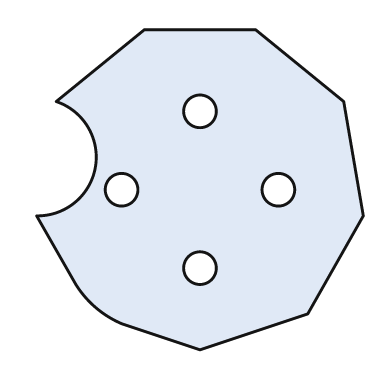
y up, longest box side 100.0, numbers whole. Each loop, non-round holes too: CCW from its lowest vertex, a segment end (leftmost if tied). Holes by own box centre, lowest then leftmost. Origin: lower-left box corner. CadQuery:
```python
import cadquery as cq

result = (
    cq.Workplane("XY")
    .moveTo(50.0, 0.0)
    .lineTo(83.0, 11.0)
    .lineTo(100.0, 41.0)
    .lineTo(94.0, 76.0)
    .lineTo(67.0, 98.0)
    .lineTo(33.0, 98.0)
    .lineTo(6.0, 76.0)
    .threePointArc((18.0, 56.0), (0.0, 41.0))
    .lineTo(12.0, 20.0)
    .threePointArc((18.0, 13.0), (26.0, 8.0))
    .close()
    .moveTo(50.0, 25.0)
    .circle(5.0)
    .moveTo(26.0, 49.0)
    .circle(5.0)
    .moveTo(74.0, 49.0)
    .circle(5.0)
    .moveTo(50.0, 73.0)
    .circle(5.0)
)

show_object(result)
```